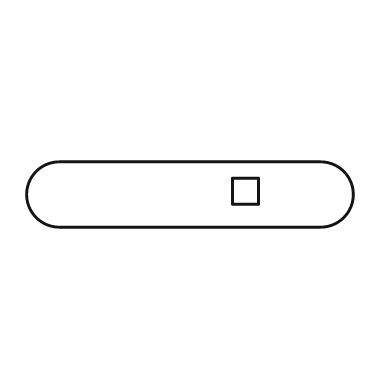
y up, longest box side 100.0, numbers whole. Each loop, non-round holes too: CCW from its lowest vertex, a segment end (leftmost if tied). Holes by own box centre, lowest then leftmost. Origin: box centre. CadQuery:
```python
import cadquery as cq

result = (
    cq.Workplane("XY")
    .moveTo(-40.0, -10.0)
    .lineTo(40.0, -10.0)
    .threePointArc((50.0, 0.0), (40.0, 10.0))
    .lineTo(-40.0, 10.0)
    .threePointArc((-50.0, 0.0), (-40.0, -10.0))
    .close()
    .moveTo(13.0, -3.0)
    .lineTo(21.0, -3.0)
    .lineTo(21.0, 5.0)
    .lineTo(13.0, 5.0)
    .close()
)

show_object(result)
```